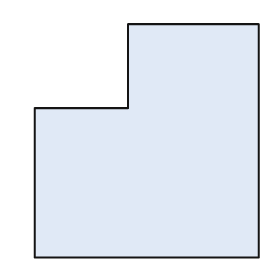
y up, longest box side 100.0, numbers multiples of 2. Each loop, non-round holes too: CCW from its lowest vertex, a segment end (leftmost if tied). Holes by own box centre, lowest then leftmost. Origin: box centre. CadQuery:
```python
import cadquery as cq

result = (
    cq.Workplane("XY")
    .moveTo(-48.0, -50.0)
    .lineTo(48.0, -50.0)
    .lineTo(48.0, 50.0)
    .lineTo(-8.0, 50.0)
    .lineTo(-8.0, 14.0)
    .lineTo(-48.0, 14.0)
    .close()
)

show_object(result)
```